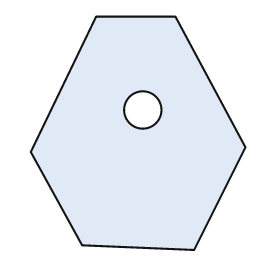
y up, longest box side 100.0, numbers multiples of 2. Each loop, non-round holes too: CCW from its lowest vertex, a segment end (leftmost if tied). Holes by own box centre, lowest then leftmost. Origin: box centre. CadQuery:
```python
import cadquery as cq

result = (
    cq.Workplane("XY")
    .moveTo(24.0, -50.0)
    .lineTo(46.0, -6.0)
    .lineTo(16.0, 50.0)
    .lineTo(-18.0, 50.0)
    .lineTo(-46.0, -8.0)
    .lineTo(-24.0, -48.0)
    .close()
    .moveTo(2.0, 10.0)
    .circle(8.0)
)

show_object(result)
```